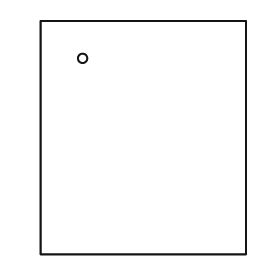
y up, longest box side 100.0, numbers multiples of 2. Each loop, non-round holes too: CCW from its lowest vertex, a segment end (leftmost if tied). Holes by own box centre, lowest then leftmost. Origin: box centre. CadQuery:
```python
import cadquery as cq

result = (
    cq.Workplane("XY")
    .moveTo(-44.0, -50.0)
    .lineTo(44.0, -50.0)
    .lineTo(44.0, 50.0)
    .lineTo(-44.0, 50.0)
    .close()
    .moveTo(-26.0, 34.0)
    .circle(2.0)
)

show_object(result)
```